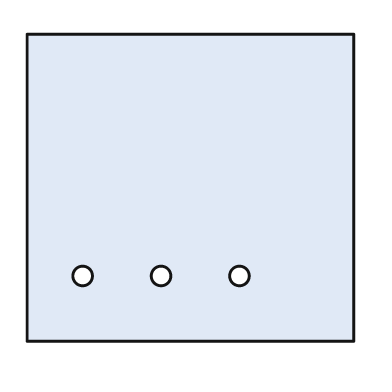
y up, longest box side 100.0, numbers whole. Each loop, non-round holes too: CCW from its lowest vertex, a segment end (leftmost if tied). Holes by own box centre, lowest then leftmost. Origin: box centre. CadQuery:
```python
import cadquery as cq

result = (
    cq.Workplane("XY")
    .moveTo(-50.0, -47.0)
    .lineTo(50.0, -47.0)
    .lineTo(50.0, 47.0)
    .lineTo(-50.0, 47.0)
    .close()
    .moveTo(-33.0, -27.0)
    .circle(3.0)
    .moveTo(-9.0, -27.0)
    .circle(3.0)
    .moveTo(15.0, -27.0)
    .circle(3.0)
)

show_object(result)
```